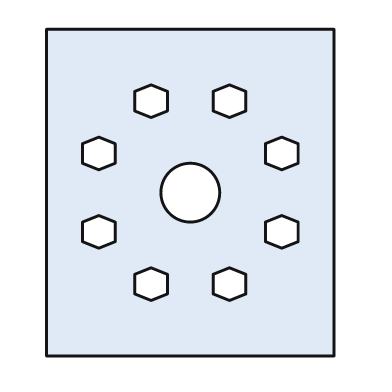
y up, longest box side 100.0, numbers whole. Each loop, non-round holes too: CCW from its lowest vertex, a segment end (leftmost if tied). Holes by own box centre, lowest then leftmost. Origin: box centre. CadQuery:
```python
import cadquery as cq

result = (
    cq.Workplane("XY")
    .moveTo(-44.0, -50.0)
    .lineTo(44.0, -50.0)
    .lineTo(44.0, 50.0)
    .lineTo(-44.0, 50.0)
    .close()
    .moveTo(-12.0, -33.0)
    .lineTo(-7.0, -31.0)
    .lineTo(-7.0, -25.0)
    .lineTo(-12.0, -23.0)
    .lineTo(-17.0, -25.0)
    .lineTo(-17.0, -31.0)
    .close()
    .moveTo(12.0, -33.0)
    .lineTo(17.0, -31.0)
    .lineTo(17.0, -25.0)
    .lineTo(12.0, -23.0)
    .lineTo(7.0, -25.0)
    .lineTo(7.0, -31.0)
    .close()
    .moveTo(-28.0, -17.0)
    .lineTo(-23.0, -15.0)
    .lineTo(-23.0, -9.0)
    .lineTo(-28.0, -7.0)
    .lineTo(-33.0, -9.0)
    .lineTo(-33.0, -15.0)
    .close()
    .moveTo(28.0, -17.0)
    .lineTo(33.0, -15.0)
    .lineTo(33.0, -9.0)
    .lineTo(28.0, -7.0)
    .lineTo(23.0, -9.0)
    .lineTo(23.0, -15.0)
    .close()
    .moveTo(0.0, 0.0)
    .circle(9.0)
    .moveTo(-28.0, 7.0)
    .lineTo(-23.0, 9.0)
    .lineTo(-23.0, 15.0)
    .lineTo(-28.0, 17.0)
    .lineTo(-33.0, 15.0)
    .lineTo(-33.0, 9.0)
    .close()
    .moveTo(28.0, 7.0)
    .lineTo(33.0, 9.0)
    .lineTo(33.0, 15.0)
    .lineTo(28.0, 17.0)
    .lineTo(23.0, 15.0)
    .lineTo(23.0, 9.0)
    .close()
    .moveTo(-12.0, 23.0)
    .lineTo(-7.0, 25.0)
    .lineTo(-7.0, 31.0)
    .lineTo(-12.0, 33.0)
    .lineTo(-17.0, 31.0)
    .lineTo(-17.0, 25.0)
    .close()
    .moveTo(12.0, 23.0)
    .lineTo(17.0, 25.0)
    .lineTo(17.0, 31.0)
    .lineTo(12.0, 33.0)
    .lineTo(7.0, 31.0)
    .lineTo(7.0, 25.0)
    .close()
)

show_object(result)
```